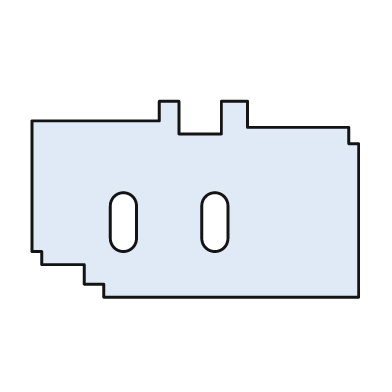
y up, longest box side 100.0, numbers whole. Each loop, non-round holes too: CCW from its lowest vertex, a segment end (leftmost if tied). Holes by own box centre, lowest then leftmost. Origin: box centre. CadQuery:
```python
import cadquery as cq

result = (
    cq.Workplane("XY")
    .moveTo(-28.0, -30.0)
    .lineTo(50.0, -30.0)
    .lineTo(50.0, 17.0)
    .lineTo(47.0, 17.0)
    .lineTo(47.0, 22.0)
    .lineTo(16.0, 22.0)
    .lineTo(16.0, 30.0)
    .lineTo(8.0, 30.0)
    .lineTo(8.0, 20.0)
    .lineTo(-5.0, 20.0)
    .lineTo(-5.0, 30.0)
    .lineTo(-11.0, 30.0)
    .lineTo(-11.0, 24.0)
    .lineTo(-50.0, 24.0)
    .lineTo(-50.0, -16.0)
    .lineTo(-47.0, -16.0)
    .lineTo(-47.0, -20.0)
    .lineTo(-34.0, -20.0)
    .lineTo(-34.0, -26.0)
    .lineTo(-28.0, -26.0)
    .close()
    .moveTo(-26.0, -12.0)
    .threePointArc((-22.0, -16.0), (-18.0, -12.0))
    .lineTo(-18.0, -2.0)
    .threePointArc((-22.0, 2.0), (-26.0, -2.0))
    .close()
    .moveTo(2.0, -12.0)
    .threePointArc((6.0, -16.0), (10.0, -12.0))
    .lineTo(10.0, -2.0)
    .threePointArc((6.0, 2.0), (2.0, -2.0))
    .close()
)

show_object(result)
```